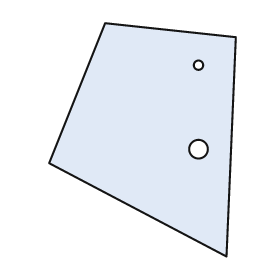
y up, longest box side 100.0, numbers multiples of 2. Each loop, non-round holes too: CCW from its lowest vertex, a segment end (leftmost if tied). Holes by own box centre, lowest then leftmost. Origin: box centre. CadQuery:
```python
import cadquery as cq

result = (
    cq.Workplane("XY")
    .moveTo(36.0, -50.0)
    .lineTo(40.0, 44.0)
    .lineTo(-16.0, 50.0)
    .lineTo(-40.0, -10.0)
    .close()
    .moveTo(24.0, -4.0)
    .circle(4.0)
    .moveTo(24.0, 32.0)
    .circle(2.0)
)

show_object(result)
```